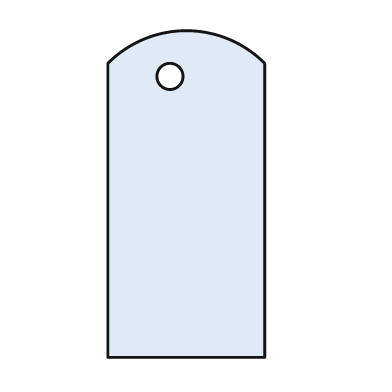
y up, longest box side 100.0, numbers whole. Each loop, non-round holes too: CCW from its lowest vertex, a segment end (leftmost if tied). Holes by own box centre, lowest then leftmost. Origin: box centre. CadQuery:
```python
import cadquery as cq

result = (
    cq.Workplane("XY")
    .moveTo(-24.0, -50.0)
    .lineTo(24.0, -50.0)
    .lineTo(24.0, 40.0)
    .threePointArc((0.0, 50.0), (-24.0, 40.0))
    .close()
    .moveTo(-5.0, 36.0)
    .circle(4.0)
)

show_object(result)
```